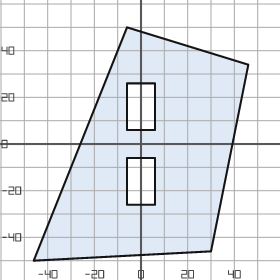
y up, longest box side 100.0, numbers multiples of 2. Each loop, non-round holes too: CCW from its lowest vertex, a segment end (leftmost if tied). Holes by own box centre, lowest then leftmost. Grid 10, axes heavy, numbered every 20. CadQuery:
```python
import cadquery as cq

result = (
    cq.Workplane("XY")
    .moveTo(-46.0, -50.0)
    .lineTo(30.0, -46.0)
    .lineTo(46.0, 34.0)
    .lineTo(-6.0, 50.0)
    .close()
    .moveTo(-6.0, -26.0)
    .lineTo(6.0, -26.0)
    .lineTo(6.0, -6.0)
    .lineTo(-6.0, -6.0)
    .close()
    .moveTo(-6.0, 6.0)
    .lineTo(6.0, 6.0)
    .lineTo(6.0, 26.0)
    .lineTo(-6.0, 26.0)
    .close()
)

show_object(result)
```